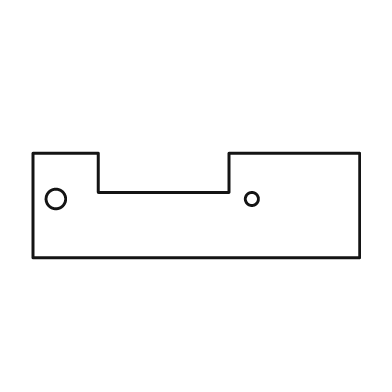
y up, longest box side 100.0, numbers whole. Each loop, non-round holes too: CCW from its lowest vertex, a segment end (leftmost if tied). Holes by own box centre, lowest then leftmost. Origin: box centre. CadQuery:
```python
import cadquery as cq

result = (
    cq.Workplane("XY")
    .moveTo(-50.0, -16.0)
    .lineTo(50.0, -16.0)
    .lineTo(50.0, 16.0)
    .lineTo(10.0, 16.0)
    .lineTo(10.0, 4.0)
    .lineTo(-30.0, 4.0)
    .lineTo(-30.0, 16.0)
    .lineTo(-50.0, 16.0)
    .close()
    .moveTo(-43.0, 2.0)
    .circle(3.0)
    .moveTo(17.0, 2.0)
    .circle(2.0)
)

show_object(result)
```